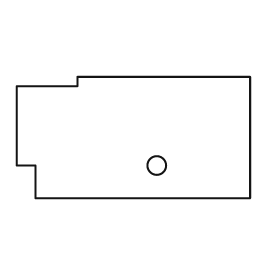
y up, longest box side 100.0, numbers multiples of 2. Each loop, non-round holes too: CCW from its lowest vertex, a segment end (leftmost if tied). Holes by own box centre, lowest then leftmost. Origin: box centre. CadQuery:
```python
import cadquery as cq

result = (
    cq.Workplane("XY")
    .moveTo(-42.0, -26.0)
    .lineTo(50.0, -26.0)
    .lineTo(50.0, 26.0)
    .lineTo(-24.0, 26.0)
    .lineTo(-24.0, 22.0)
    .lineTo(-50.0, 22.0)
    .lineTo(-50.0, -12.0)
    .lineTo(-42.0, -12.0)
    .close()
    .moveTo(10.0, -12.0)
    .circle(4.0)
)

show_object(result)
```